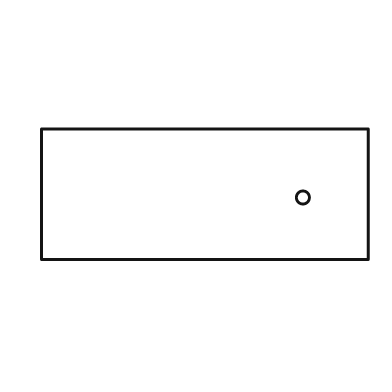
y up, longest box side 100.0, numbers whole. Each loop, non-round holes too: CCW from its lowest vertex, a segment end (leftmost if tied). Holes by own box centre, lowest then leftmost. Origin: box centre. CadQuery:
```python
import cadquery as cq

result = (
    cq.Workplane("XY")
    .moveTo(-50.0, -20.0)
    .lineTo(50.0, -20.0)
    .lineTo(50.0, 20.0)
    .lineTo(-50.0, 20.0)
    .close()
    .moveTo(30.0, -1.0)
    .circle(2.0)
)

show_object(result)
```